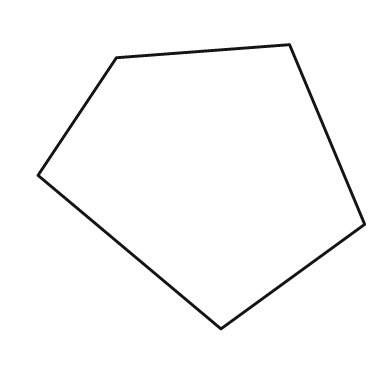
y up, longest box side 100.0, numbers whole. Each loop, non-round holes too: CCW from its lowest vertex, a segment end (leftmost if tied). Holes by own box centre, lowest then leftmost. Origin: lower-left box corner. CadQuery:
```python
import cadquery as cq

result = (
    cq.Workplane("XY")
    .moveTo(56.0, 0.0)
    .lineTo(100.0, 32.0)
    .lineTo(77.0, 87.0)
    .lineTo(24.0, 83.0)
    .lineTo(0.0, 47.0)
    .close()
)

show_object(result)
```